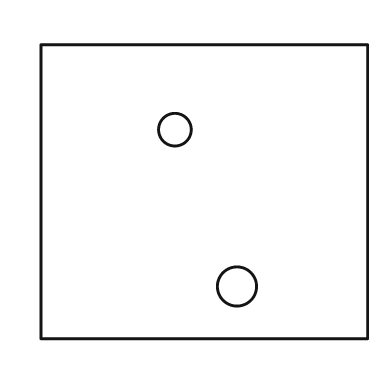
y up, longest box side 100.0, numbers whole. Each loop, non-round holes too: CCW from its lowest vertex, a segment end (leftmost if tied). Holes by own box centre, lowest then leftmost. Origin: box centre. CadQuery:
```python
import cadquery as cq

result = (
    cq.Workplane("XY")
    .moveTo(-50.0, -45.0)
    .lineTo(50.0, -45.0)
    .lineTo(50.0, 45.0)
    .lineTo(-50.0, 45.0)
    .close()
    .moveTo(10.0, -29.0)
    .circle(6.0)
    .moveTo(-9.0, 19.0)
    .circle(5.0)
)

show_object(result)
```